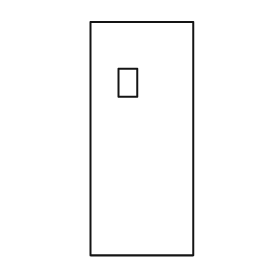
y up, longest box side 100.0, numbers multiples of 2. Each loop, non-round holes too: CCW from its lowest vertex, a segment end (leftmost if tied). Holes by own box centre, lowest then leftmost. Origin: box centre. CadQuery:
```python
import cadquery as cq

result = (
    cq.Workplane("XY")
    .moveTo(-22.0, -50.0)
    .lineTo(22.0, -50.0)
    .lineTo(22.0, 50.0)
    .lineTo(-22.0, 50.0)
    .close()
    .moveTo(-10.0, 18.0)
    .lineTo(-2.0, 18.0)
    .lineTo(-2.0, 30.0)
    .lineTo(-10.0, 30.0)
    .close()
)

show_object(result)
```